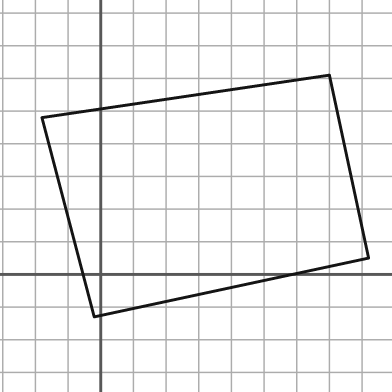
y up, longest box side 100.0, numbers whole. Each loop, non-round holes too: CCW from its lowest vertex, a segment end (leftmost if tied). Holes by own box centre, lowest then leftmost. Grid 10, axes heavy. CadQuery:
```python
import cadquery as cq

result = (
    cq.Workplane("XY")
    .moveTo(-2.0, -13.0)
    .lineTo(82.0, 5.0)
    .lineTo(70.0, 61.0)
    .lineTo(-18.0, 48.0)
    .close()
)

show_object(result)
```